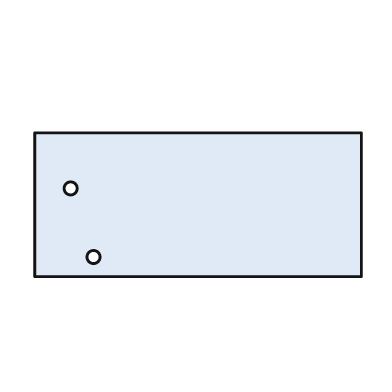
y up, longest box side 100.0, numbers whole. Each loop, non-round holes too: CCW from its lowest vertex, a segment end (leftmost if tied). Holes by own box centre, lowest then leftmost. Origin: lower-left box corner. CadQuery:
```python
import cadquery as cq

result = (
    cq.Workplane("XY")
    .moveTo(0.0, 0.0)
    .lineTo(100.0, 0.0)
    .lineTo(100.0, 44.0)
    .lineTo(0.0, 44.0)
    .close()
    .moveTo(18.0, 6.0)
    .circle(2.0)
    .moveTo(11.0, 27.0)
    .circle(2.0)
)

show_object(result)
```